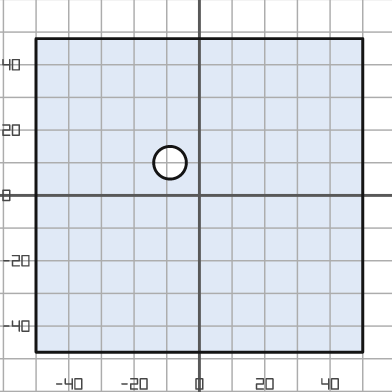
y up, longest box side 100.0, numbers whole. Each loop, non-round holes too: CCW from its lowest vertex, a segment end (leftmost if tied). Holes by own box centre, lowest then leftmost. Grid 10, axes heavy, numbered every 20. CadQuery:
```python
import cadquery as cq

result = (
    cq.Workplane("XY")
    .moveTo(-50.0, -48.0)
    .lineTo(50.0, -48.0)
    .lineTo(50.0, 48.0)
    .lineTo(-50.0, 48.0)
    .close()
    .moveTo(-9.0, 10.0)
    .circle(5.0)
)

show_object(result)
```